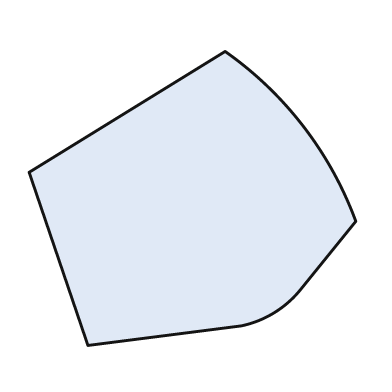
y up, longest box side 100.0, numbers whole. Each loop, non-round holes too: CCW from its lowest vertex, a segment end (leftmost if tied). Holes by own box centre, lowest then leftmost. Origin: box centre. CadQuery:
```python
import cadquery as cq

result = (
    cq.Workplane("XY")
    .moveTo(-32.0, -45.0)
    .lineTo(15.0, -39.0)
    .threePointArc((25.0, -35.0), (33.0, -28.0))
    .lineTo(50.0, -7.0)
    .threePointArc((34.0, 22.0), (10.0, 45.0))
    .lineTo(-50.0, 8.0)
    .close()
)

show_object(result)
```